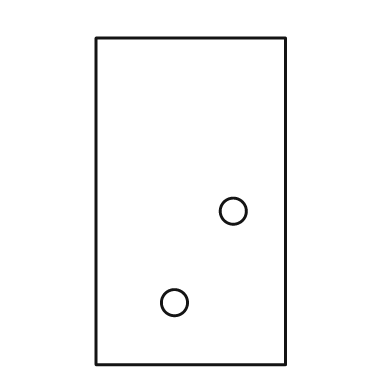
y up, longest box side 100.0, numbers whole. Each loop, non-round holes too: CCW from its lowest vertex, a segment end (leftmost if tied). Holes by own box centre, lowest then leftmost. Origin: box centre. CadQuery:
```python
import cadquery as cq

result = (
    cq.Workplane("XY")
    .moveTo(-29.0, -50.0)
    .lineTo(29.0, -50.0)
    .lineTo(29.0, 50.0)
    .lineTo(-29.0, 50.0)
    .close()
    .moveTo(-5.0, -31.0)
    .circle(4.0)
    .moveTo(13.0, -3.0)
    .circle(4.0)
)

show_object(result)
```